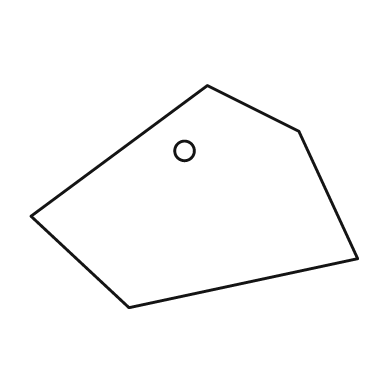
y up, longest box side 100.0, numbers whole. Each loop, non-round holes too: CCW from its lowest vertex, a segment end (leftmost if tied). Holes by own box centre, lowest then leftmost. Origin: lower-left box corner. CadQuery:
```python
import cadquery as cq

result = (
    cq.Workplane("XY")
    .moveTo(30.0, 0.0)
    .lineTo(100.0, 15.0)
    .lineTo(82.0, 54.0)
    .lineTo(54.0, 68.0)
    .lineTo(0.0, 28.0)
    .close()
    .moveTo(47.0, 48.0)
    .circle(3.0)
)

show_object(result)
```